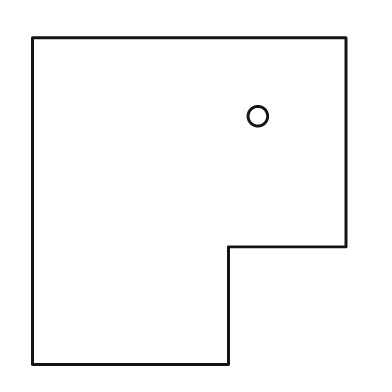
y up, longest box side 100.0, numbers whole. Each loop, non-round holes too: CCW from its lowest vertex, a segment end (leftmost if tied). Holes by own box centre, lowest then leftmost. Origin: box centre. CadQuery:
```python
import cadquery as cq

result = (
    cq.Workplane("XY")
    .moveTo(-48.0, -50.0)
    .lineTo(12.0, -50.0)
    .lineTo(12.0, -14.0)
    .lineTo(48.0, -14.0)
    .lineTo(48.0, 50.0)
    .lineTo(-48.0, 50.0)
    .close()
    .moveTo(21.0, 26.0)
    .circle(3.0)
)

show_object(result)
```